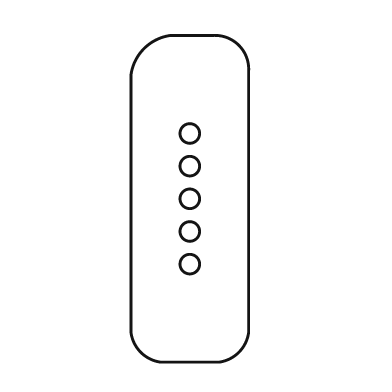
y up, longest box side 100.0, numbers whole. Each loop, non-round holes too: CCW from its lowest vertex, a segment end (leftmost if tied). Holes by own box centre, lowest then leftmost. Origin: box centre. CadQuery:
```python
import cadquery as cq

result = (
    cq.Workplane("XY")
    .moveTo(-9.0, -50.0)
    .lineTo(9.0, -50.0)
    .threePointArc((15.0, -47.0), (18.0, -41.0))
    .lineTo(18.0, 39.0)
    .threePointArc((15.0, 47.0), (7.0, 50.0))
    .lineTo(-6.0, 50.0)
    .threePointArc((-14.0, 46.0), (-18.0, 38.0))
    .lineTo(-18.0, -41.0)
    .threePointArc((-15.0, -47.0), (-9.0, -50.0))
    .close()
    .moveTo(0.0, -20.0)
    .circle(3.0)
    .moveTo(0.0, -10.0)
    .circle(3.0)
    .moveTo(0.0, 0.0)
    .circle(3.0)
    .moveTo(0.0, 10.0)
    .circle(3.0)
    .moveTo(0.0, 20.0)
    .circle(3.0)
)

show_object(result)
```